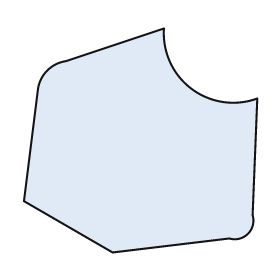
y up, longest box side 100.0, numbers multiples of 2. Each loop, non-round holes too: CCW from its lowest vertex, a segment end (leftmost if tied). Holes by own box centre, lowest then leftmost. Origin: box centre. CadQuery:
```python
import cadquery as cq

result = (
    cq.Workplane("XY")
    .moveTo(-12.0, -48.0)
    .lineTo(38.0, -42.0)
    .threePointArc((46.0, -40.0), (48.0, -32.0))
    .lineTo(50.0, 18.0)
    .threePointArc((22.0, 22.0), (10.0, 48.0))
    .lineTo(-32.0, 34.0)
    .threePointArc((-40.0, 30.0), (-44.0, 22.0))
    .lineTo(-50.0, -26.0)
    .close()
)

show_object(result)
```